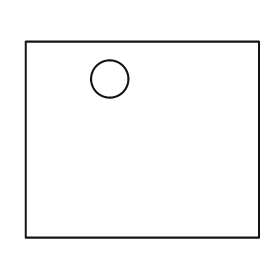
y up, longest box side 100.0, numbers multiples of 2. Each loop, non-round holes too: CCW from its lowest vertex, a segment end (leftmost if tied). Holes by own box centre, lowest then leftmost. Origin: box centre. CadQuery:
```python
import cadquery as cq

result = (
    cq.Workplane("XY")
    .moveTo(-50.0, -42.0)
    .lineTo(50.0, -42.0)
    .lineTo(50.0, 42.0)
    .lineTo(-50.0, 42.0)
    .close()
    .moveTo(-14.0, 26.0)
    .circle(8.0)
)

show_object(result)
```